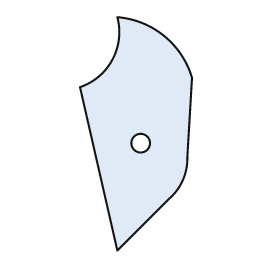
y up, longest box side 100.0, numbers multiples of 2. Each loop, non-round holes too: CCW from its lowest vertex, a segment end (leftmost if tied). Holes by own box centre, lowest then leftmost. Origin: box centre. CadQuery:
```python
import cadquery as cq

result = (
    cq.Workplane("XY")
    .moveTo(-8.0, -50.0)
    .lineTo(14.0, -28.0)
    .threePointArc((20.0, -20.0), (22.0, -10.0))
    .lineTo(24.0, 24.0)
    .threePointArc((12.0, 42.0), (-8.0, 50.0))
    .threePointArc((-10.0, 32.0), (-24.0, 20.0))
    .close()
    .moveTo(2.0, -4.0)
    .circle(4.0)
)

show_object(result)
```